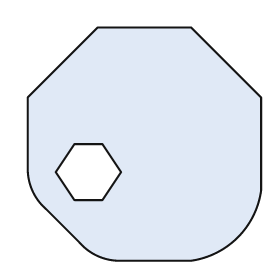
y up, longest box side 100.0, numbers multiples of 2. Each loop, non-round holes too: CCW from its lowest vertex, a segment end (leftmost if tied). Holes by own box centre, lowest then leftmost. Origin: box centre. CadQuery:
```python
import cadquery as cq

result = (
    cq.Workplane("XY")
    .moveTo(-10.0, -50.0)
    .lineTo(20.0, -50.0)
    .threePointArc((40.0, -40.0), (50.0, -20.0))
    .lineTo(50.0, 20.0)
    .lineTo(20.0, 50.0)
    .lineTo(-20.0, 50.0)
    .lineTo(-50.0, 20.0)
    .lineTo(-50.0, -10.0)
    .threePointArc((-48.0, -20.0), (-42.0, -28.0))
    .lineTo(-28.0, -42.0)
    .threePointArc((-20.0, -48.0), (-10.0, -50.0))
    .close()
    .moveTo(-30.0, -24.0)
    .lineTo(-18.0, -24.0)
    .lineTo(-10.0, -12.0)
    .lineTo(-18.0, 0.0)
    .lineTo(-30.0, 0.0)
    .lineTo(-38.0, -12.0)
    .close()
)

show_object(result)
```